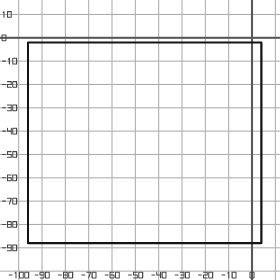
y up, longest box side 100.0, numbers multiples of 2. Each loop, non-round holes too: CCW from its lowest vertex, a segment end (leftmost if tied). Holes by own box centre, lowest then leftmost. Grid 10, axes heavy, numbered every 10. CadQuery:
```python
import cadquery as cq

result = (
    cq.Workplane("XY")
    .moveTo(-96.0, -88.0)
    .lineTo(4.0, -88.0)
    .lineTo(4.0, -2.0)
    .lineTo(-96.0, -2.0)
    .close()
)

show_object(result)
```